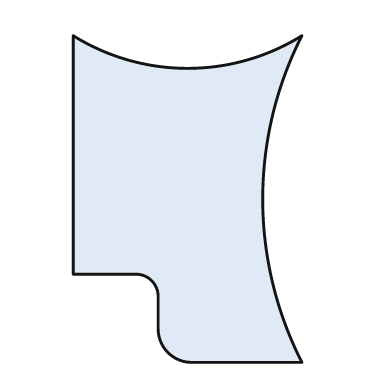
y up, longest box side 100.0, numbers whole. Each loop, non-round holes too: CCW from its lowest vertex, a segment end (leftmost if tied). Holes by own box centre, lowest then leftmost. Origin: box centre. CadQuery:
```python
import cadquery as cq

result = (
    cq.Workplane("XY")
    .moveTo(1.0, -50.0)
    .lineTo(35.0, -50.0)
    .threePointArc((23.0, 0.0), (35.0, 50.0))
    .threePointArc((0.0, 40.0), (-35.0, 50.0))
    .lineTo(-35.0, -23.0)
    .lineTo(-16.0, -23.0)
    .threePointArc((-11.0, -25.0), (-9.0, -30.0))
    .lineTo(-9.0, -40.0)
    .threePointArc((-6.0, -47.0), (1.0, -50.0))
    .close()
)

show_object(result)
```